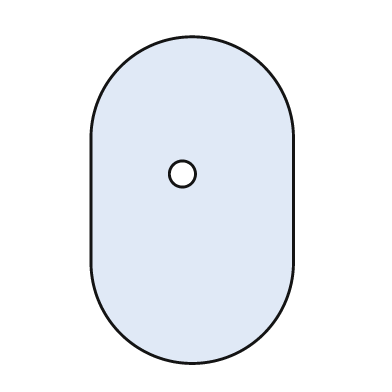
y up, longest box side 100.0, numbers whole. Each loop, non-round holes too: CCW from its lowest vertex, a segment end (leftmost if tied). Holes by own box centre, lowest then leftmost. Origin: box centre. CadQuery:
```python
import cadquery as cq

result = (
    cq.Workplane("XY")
    .moveTo(-31.0, -19.0)
    .threePointArc((0.0, -50.0), (31.0, -19.0))
    .lineTo(31.0, 19.0)
    .threePointArc((0.0, 50.0), (-31.0, 19.0))
    .close()
    .moveTo(-3.0, 8.0)
    .circle(4.0)
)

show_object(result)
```